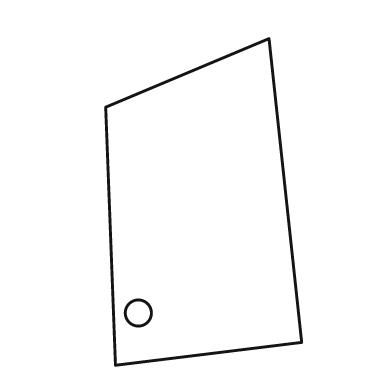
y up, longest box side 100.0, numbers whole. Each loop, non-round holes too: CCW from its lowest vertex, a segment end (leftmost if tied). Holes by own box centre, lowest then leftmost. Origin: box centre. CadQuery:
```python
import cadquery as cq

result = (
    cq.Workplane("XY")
    .moveTo(-27.0, -50.0)
    .lineTo(30.0, -43.0)
    .lineTo(20.0, 50.0)
    .lineTo(-30.0, 29.0)
    .close()
    .moveTo(-20.0, -34.0)
    .circle(4.0)
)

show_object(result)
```